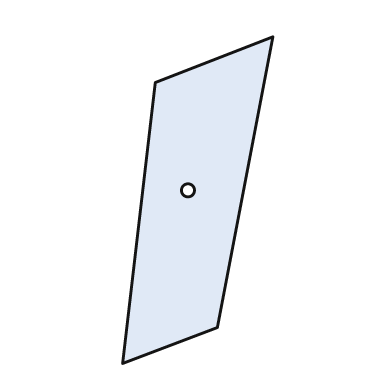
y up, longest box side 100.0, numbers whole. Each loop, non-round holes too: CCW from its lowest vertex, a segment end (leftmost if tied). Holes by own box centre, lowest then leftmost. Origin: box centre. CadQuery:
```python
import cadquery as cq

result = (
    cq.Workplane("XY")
    .moveTo(-23.0, -50.0)
    .lineTo(6.0, -39.0)
    .lineTo(23.0, 50.0)
    .lineTo(-13.0, 36.0)
    .close()
    .moveTo(-3.0, 3.0)
    .circle(2.0)
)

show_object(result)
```